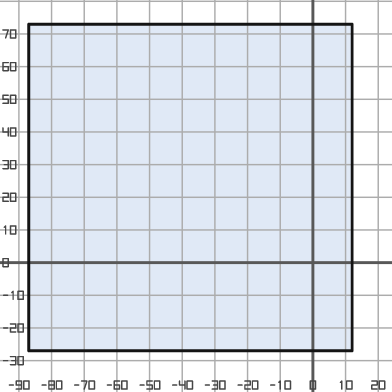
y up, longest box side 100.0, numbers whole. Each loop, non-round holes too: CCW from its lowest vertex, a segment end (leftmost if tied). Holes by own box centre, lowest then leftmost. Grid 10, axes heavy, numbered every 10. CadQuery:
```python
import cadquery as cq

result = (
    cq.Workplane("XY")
    .moveTo(-87.0, -27.0)
    .lineTo(12.0, -27.0)
    .lineTo(12.0, 73.0)
    .lineTo(-87.0, 73.0)
    .close()
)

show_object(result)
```